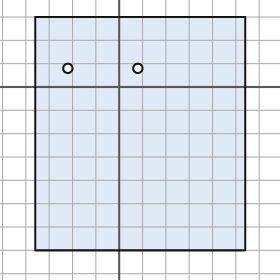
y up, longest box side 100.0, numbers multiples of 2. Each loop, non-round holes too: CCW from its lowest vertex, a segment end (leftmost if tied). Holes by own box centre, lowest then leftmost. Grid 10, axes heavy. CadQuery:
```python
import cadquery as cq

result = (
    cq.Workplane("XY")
    .moveTo(-36.0, -70.0)
    .lineTo(54.0, -70.0)
    .lineTo(54.0, 30.0)
    .lineTo(-36.0, 30.0)
    .close()
    .moveTo(-22.0, 8.0)
    .circle(2.0)
    .moveTo(8.0, 8.0)
    .circle(2.0)
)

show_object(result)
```